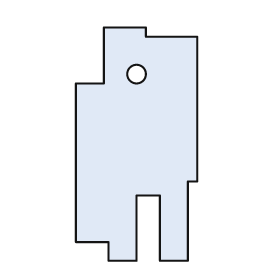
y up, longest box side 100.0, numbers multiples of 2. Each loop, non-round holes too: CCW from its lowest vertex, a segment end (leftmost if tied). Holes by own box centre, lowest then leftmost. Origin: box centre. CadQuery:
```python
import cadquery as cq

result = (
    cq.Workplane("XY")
    .moveTo(-12.0, -50.0)
    .lineTo(0.0, -50.0)
    .lineTo(0.0, -22.0)
    .lineTo(10.0, -22.0)
    .lineTo(10.0, -50.0)
    .lineTo(22.0, -50.0)
    .lineTo(22.0, -16.0)
    .lineTo(26.0, -16.0)
    .lineTo(26.0, 46.0)
    .lineTo(4.0, 46.0)
    .lineTo(4.0, 50.0)
    .lineTo(-14.0, 50.0)
    .lineTo(-14.0, 26.0)
    .lineTo(-26.0, 26.0)
    .lineTo(-26.0, -42.0)
    .lineTo(-12.0, -42.0)
    .close()
    .moveTo(0.0, 30.0)
    .circle(4.0)
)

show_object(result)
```